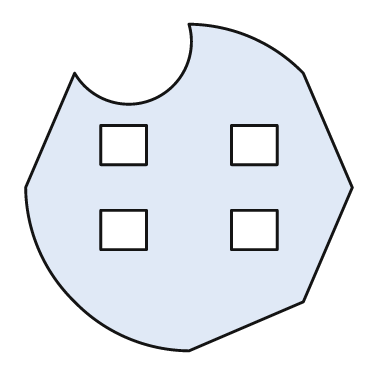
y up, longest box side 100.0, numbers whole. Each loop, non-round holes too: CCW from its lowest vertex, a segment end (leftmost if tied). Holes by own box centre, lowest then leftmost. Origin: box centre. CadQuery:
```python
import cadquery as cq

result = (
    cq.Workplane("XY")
    .moveTo(0.0, -50.0)
    .lineTo(35.0, -35.0)
    .lineTo(50.0, 0.0)
    .lineTo(35.0, 35.0)
    .threePointArc((19.0, 46.0), (0.0, 50.0))
    .threePointArc((-11.0, 27.0), (-35.0, 35.0))
    .lineTo(-50.0, 0.0)
    .threePointArc((-46.0, -19.0), (-35.0, -35.0))
    .threePointArc((-19.0, -46.0), (0.0, -50.0))
    .close()
    .moveTo(-27.0, -19.0)
    .lineTo(-13.0, -19.0)
    .lineTo(-13.0, -7.0)
    .lineTo(-27.0, -7.0)
    .close()
    .moveTo(13.0, -19.0)
    .lineTo(27.0, -19.0)
    .lineTo(27.0, -7.0)
    .lineTo(13.0, -7.0)
    .close()
    .moveTo(-27.0, 7.0)
    .lineTo(-13.0, 7.0)
    .lineTo(-13.0, 19.0)
    .lineTo(-27.0, 19.0)
    .close()
    .moveTo(13.0, 7.0)
    .lineTo(27.0, 7.0)
    .lineTo(27.0, 19.0)
    .lineTo(13.0, 19.0)
    .close()
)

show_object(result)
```